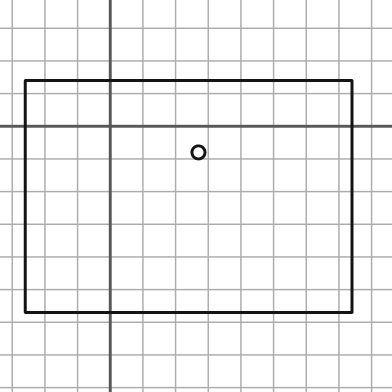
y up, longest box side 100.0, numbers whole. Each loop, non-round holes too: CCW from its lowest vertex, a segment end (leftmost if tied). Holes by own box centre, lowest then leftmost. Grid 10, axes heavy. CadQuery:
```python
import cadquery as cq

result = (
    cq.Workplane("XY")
    .moveTo(-26.0, -57.0)
    .lineTo(74.0, -57.0)
    .lineTo(74.0, 14.0)
    .lineTo(-26.0, 14.0)
    .close()
    .moveTo(27.0, -8.0)
    .circle(2.0)
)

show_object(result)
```